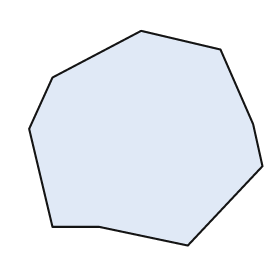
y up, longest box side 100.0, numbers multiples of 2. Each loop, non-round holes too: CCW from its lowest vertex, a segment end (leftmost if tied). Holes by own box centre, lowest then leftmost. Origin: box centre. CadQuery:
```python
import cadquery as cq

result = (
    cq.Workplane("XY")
    .moveTo(18.0, -46.0)
    .lineTo(50.0, -12.0)
    .lineTo(46.0, 6.0)
    .lineTo(32.0, 38.0)
    .lineTo(-2.0, 46.0)
    .lineTo(-40.0, 26.0)
    .lineTo(-50.0, 4.0)
    .lineTo(-40.0, -38.0)
    .lineTo(-20.0, -38.0)
    .close()
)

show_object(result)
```